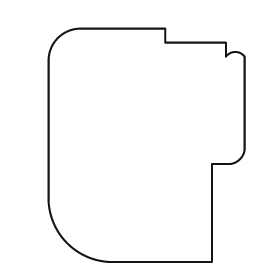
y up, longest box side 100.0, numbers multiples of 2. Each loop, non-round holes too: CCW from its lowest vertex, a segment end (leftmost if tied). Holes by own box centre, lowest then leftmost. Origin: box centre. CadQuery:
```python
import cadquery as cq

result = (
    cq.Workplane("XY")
    .moveTo(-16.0, -50.0)
    .lineTo(28.0, -50.0)
    .lineTo(28.0, -8.0)
    .lineTo(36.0, -8.0)
    .threePointArc((40.0, -6.0), (42.0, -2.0))
    .lineTo(42.0, 38.0)
    .threePointArc((38.0, 40.0), (34.0, 38.0))
    .lineTo(34.0, 44.0)
    .lineTo(8.0, 44.0)
    .lineTo(8.0, 50.0)
    .lineTo(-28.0, 50.0)
    .threePointArc((-38.0, 46.0), (-42.0, 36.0))
    .lineTo(-42.0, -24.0)
    .threePointArc((-34.0, -42.0), (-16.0, -50.0))
    .close()
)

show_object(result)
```